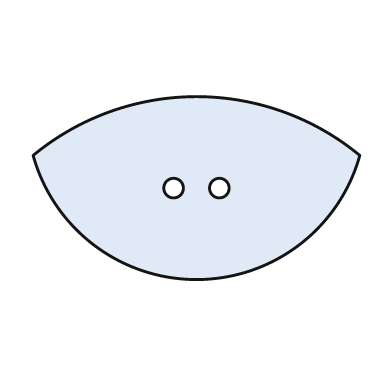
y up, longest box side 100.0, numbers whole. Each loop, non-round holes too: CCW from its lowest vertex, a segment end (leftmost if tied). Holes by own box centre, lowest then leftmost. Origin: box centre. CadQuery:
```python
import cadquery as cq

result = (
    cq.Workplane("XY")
    .moveTo(-50.0, 10.0)
    .threePointArc((0.0, -28.0), (50.0, 10.0))
    .threePointArc((0.0, 28.0), (-50.0, 10.0))
    .close()
    .moveTo(-7.0, 0.0)
    .circle(3.0)
    .moveTo(7.0, 0.0)
    .circle(3.0)
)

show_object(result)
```